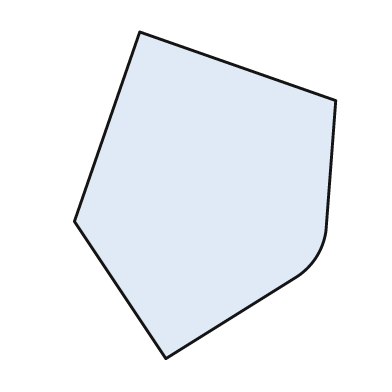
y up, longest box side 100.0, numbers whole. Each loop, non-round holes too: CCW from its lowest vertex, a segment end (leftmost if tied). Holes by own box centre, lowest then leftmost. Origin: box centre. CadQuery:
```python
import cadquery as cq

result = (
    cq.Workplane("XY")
    .moveTo(-12.0, -50.0)
    .lineTo(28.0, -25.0)
    .threePointArc((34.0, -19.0), (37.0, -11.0))
    .lineTo(40.0, 29.0)
    .lineTo(-20.0, 50.0)
    .lineTo(-40.0, -8.0)
    .close()
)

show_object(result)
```